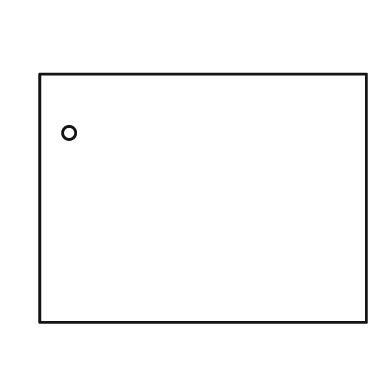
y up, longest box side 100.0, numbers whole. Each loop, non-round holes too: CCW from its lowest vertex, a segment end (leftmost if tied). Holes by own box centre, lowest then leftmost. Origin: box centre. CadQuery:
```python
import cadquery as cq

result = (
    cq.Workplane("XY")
    .moveTo(-50.0, -38.0)
    .lineTo(50.0, -38.0)
    .lineTo(50.0, 38.0)
    .lineTo(-50.0, 38.0)
    .close()
    .moveTo(-41.0, 20.0)
    .circle(2.0)
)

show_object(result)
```